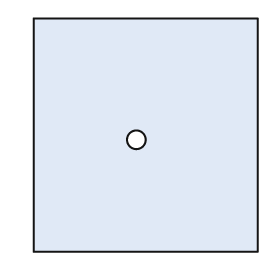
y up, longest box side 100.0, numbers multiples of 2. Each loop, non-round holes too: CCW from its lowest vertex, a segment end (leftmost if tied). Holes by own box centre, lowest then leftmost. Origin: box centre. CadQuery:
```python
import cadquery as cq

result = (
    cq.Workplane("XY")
    .moveTo(-48.0, -50.0)
    .lineTo(48.0, -50.0)
    .lineTo(48.0, 50.0)
    .lineTo(-48.0, 50.0)
    .close()
    .moveTo(-4.0, -2.0)
    .circle(4.0)
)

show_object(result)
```